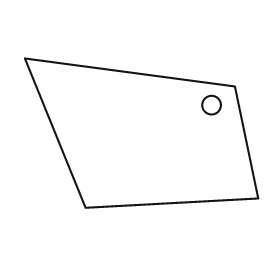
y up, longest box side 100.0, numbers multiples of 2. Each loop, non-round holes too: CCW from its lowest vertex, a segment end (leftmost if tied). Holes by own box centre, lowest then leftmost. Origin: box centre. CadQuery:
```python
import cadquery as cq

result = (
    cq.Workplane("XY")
    .moveTo(-24.0, -32.0)
    .lineTo(50.0, -28.0)
    .lineTo(40.0, 20.0)
    .lineTo(-50.0, 32.0)
    .close()
    .moveTo(30.0, 12.0)
    .circle(4.0)
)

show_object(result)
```